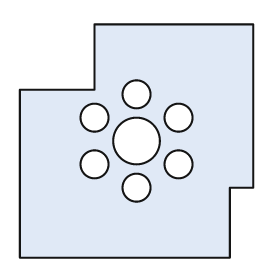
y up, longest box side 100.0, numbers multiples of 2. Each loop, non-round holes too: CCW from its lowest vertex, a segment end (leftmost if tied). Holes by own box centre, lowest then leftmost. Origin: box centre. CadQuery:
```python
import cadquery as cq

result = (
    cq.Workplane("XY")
    .moveTo(-50.0, -50.0)
    .lineTo(40.0, -50.0)
    .lineTo(40.0, -20.0)
    .lineTo(50.0, -20.0)
    .lineTo(50.0, 50.0)
    .lineTo(-18.0, 50.0)
    .lineTo(-18.0, 22.0)
    .lineTo(-50.0, 22.0)
    .close()
    .moveTo(0.0, -20.0)
    .circle(6.0)
    .moveTo(-18.0, -10.0)
    .circle(6.0)
    .moveTo(18.0, -10.0)
    .circle(6.0)
    .moveTo(0.0, 0.0)
    .circle(10.0)
    .moveTo(-18.0, 10.0)
    .circle(6.0)
    .moveTo(18.0, 10.0)
    .circle(6.0)
    .moveTo(0.0, 20.0)
    .circle(6.0)
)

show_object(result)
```